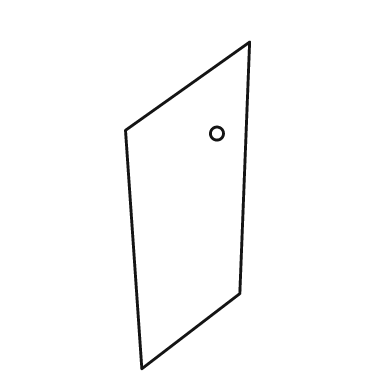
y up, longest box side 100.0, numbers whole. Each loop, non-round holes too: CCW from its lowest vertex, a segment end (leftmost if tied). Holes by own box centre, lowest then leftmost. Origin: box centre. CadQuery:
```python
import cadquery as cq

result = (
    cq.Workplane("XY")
    .moveTo(-14.0, -50.0)
    .lineTo(16.0, -27.0)
    .lineTo(19.0, 50.0)
    .lineTo(-19.0, 23.0)
    .close()
    .moveTo(9.0, 22.0)
    .circle(2.0)
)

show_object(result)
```